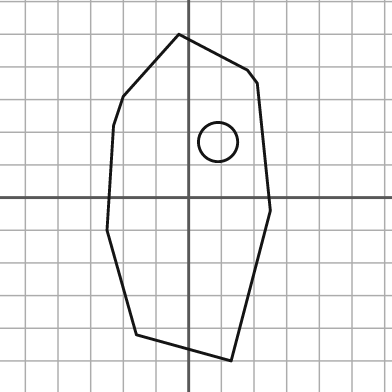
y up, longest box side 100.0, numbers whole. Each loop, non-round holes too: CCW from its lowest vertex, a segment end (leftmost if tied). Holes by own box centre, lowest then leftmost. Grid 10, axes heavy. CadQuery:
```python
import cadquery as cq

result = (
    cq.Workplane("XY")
    .moveTo(13.0, -50.0)
    .lineTo(25.0, -4.0)
    .lineTo(21.0, 35.0)
    .lineTo(18.0, 39.0)
    .lineTo(-3.0, 50.0)
    .lineTo(-20.0, 31.0)
    .lineTo(-23.0, 22.0)
    .lineTo(-25.0, -10.0)
    .lineTo(-16.0, -42.0)
    .close()
    .moveTo(9.0, 17.0)
    .circle(6.0)
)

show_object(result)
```